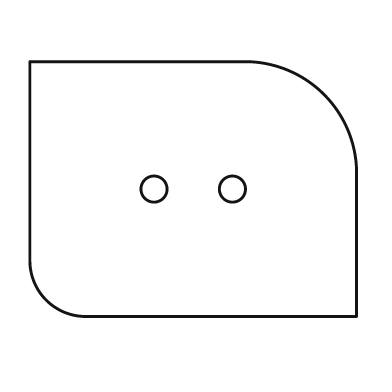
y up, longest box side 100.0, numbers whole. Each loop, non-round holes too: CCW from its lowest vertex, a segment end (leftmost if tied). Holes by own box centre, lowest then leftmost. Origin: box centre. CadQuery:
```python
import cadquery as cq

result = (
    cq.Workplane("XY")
    .moveTo(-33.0, -39.0)
    .lineTo(50.0, -39.0)
    .lineTo(50.0, 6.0)
    .threePointArc((40.0, 29.0), (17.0, 39.0))
    .lineTo(-50.0, 39.0)
    .lineTo(-50.0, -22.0)
    .threePointArc((-45.0, -34.0), (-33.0, -39.0))
    .close()
    .moveTo(-12.0, 0.0)
    .circle(4.0)
    .moveTo(12.0, 0.0)
    .circle(4.0)
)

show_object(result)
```